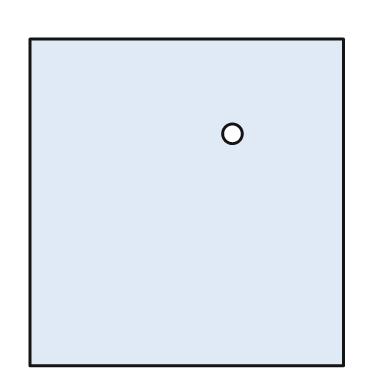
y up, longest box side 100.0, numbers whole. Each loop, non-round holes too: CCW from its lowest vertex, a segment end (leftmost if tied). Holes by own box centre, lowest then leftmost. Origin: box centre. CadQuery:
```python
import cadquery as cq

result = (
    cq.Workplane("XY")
    .moveTo(-48.0, -50.0)
    .lineTo(48.0, -50.0)
    .lineTo(48.0, 50.0)
    .lineTo(-48.0, 50.0)
    .close()
    .moveTo(14.0, 21.0)
    .circle(3.0)
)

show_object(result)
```